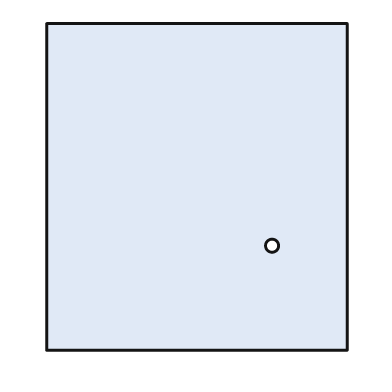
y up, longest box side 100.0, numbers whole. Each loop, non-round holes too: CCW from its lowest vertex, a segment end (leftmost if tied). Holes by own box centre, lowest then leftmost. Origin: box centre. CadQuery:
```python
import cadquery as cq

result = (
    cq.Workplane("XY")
    .moveTo(-46.0, -50.0)
    .lineTo(46.0, -50.0)
    .lineTo(46.0, 50.0)
    .lineTo(-46.0, 50.0)
    .close()
    .moveTo(23.0, -18.0)
    .circle(2.0)
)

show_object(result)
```